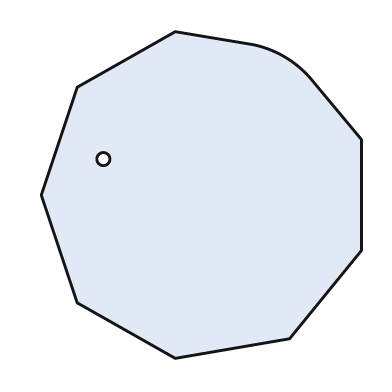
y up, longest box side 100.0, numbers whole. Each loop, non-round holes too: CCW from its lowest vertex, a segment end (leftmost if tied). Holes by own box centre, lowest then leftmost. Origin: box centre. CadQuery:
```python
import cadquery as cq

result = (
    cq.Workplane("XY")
    .moveTo(-8.0, -50.0)
    .lineTo(27.0, -44.0)
    .lineTo(49.0, -17.0)
    .lineTo(49.0, 17.0)
    .lineTo(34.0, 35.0)
    .threePointArc((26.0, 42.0), (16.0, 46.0))
    .lineTo(-8.0, 50.0)
    .lineTo(-38.0, 33.0)
    .lineTo(-49.0, 0.0)
    .lineTo(-38.0, -33.0)
    .close()
    .moveTo(-30.0, 11.0)
    .circle(2.0)
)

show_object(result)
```